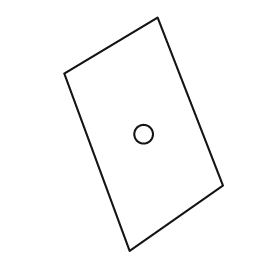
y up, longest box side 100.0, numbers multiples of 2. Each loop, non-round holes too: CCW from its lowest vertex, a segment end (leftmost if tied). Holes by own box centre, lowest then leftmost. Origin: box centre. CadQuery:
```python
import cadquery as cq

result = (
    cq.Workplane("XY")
    .moveTo(-6.0, -50.0)
    .lineTo(34.0, -22.0)
    .lineTo(6.0, 50.0)
    .lineTo(-34.0, 26.0)
    .close()
    .moveTo(0.0, 0.0)
    .circle(4.0)
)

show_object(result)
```